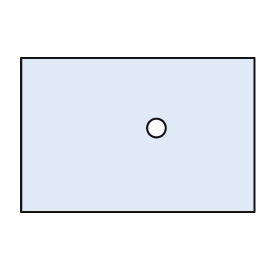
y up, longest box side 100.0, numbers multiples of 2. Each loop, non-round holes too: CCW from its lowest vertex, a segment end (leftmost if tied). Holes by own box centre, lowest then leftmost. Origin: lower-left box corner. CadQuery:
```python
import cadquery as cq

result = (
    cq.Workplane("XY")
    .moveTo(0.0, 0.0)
    .lineTo(100.0, 0.0)
    .lineTo(100.0, 66.0)
    .lineTo(0.0, 66.0)
    .close()
    .moveTo(58.0, 36.0)
    .circle(4.0)
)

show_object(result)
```